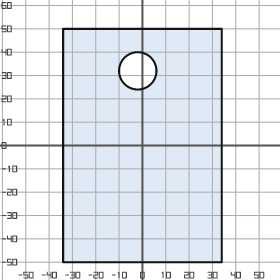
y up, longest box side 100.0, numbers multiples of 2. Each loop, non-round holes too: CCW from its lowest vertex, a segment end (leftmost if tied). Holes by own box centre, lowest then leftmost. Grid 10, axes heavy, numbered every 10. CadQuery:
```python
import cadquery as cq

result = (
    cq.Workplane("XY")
    .moveTo(-34.0, -50.0)
    .lineTo(34.0, -50.0)
    .lineTo(34.0, 50.0)
    .lineTo(-34.0, 50.0)
    .close()
    .moveTo(-2.0, 32.0)
    .circle(8.0)
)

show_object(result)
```